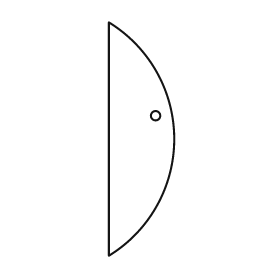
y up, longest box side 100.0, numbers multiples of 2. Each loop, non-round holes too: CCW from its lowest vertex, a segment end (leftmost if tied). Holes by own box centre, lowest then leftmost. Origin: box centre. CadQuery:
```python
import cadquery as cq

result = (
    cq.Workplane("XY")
    .moveTo(-14.0, -50.0)
    .threePointArc((14.0, 0.0), (-14.0, 50.0))
    .close()
    .moveTo(6.0, 10.0)
    .circle(2.0)
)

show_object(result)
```